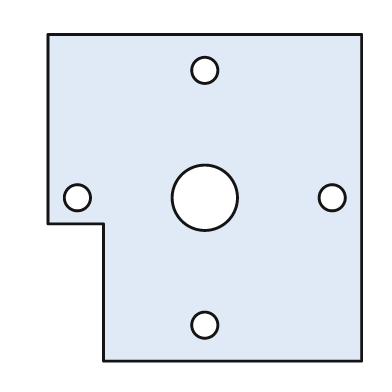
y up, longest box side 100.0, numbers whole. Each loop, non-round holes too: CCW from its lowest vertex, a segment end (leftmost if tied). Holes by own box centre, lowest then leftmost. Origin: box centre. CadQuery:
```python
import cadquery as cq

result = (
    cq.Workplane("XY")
    .moveTo(-31.0, -50.0)
    .lineTo(48.0, -50.0)
    .lineTo(48.0, 50.0)
    .lineTo(-48.0, 50.0)
    .lineTo(-48.0, -8.0)
    .lineTo(-31.0, -8.0)
    .close()
    .moveTo(0.0, -39.0)
    .circle(4.0)
    .moveTo(-39.0, 0.0)
    .circle(4.0)
    .moveTo(0.0, 0.0)
    .circle(10.0)
    .moveTo(39.0, 0.0)
    .circle(4.0)
    .moveTo(0.0, 39.0)
    .circle(4.0)
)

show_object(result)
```